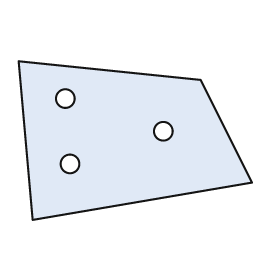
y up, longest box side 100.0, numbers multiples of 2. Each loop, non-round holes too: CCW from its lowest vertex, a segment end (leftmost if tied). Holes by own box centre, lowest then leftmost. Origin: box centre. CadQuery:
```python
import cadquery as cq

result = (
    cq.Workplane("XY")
    .moveTo(-44.0, -34.0)
    .lineTo(50.0, -18.0)
    .lineTo(28.0, 26.0)
    .lineTo(-50.0, 34.0)
    .close()
    .moveTo(-28.0, -10.0)
    .circle(4.0)
    .moveTo(12.0, 4.0)
    .circle(4.0)
    .moveTo(-30.0, 18.0)
    .circle(4.0)
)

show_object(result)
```